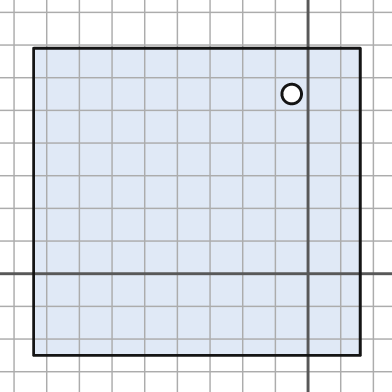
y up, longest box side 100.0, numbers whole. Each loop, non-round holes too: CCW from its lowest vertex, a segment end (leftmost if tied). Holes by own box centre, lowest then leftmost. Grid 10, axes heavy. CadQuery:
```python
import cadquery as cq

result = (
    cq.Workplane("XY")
    .moveTo(-84.0, -25.0)
    .lineTo(16.0, -25.0)
    .lineTo(16.0, 69.0)
    .lineTo(-84.0, 69.0)
    .close()
    .moveTo(-5.0, 55.0)
    .circle(3.0)
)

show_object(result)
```